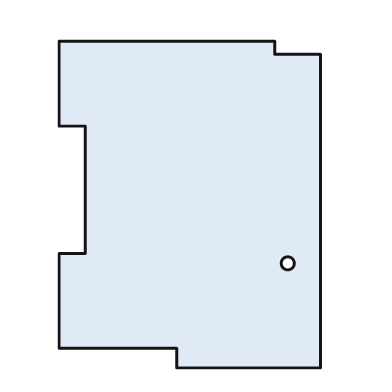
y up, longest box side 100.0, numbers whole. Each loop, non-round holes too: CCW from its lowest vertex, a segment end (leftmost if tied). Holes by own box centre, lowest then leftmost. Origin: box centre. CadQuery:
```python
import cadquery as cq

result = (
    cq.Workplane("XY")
    .moveTo(-4.0, -50.0)
    .lineTo(40.0, -50.0)
    .lineTo(40.0, 46.0)
    .lineTo(26.0, 46.0)
    .lineTo(26.0, 50.0)
    .lineTo(-40.0, 50.0)
    .lineTo(-40.0, 24.0)
    .lineTo(-32.0, 24.0)
    .lineTo(-32.0, -15.0)
    .lineTo(-40.0, -15.0)
    .lineTo(-40.0, -44.0)
    .lineTo(-4.0, -44.0)
    .close()
    .moveTo(30.0, -18.0)
    .circle(2.0)
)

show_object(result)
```